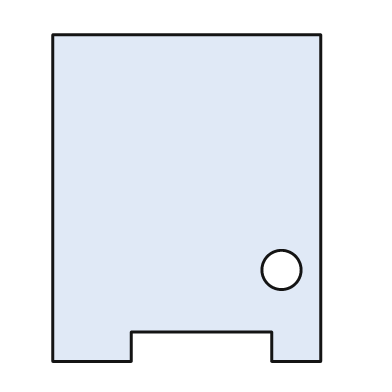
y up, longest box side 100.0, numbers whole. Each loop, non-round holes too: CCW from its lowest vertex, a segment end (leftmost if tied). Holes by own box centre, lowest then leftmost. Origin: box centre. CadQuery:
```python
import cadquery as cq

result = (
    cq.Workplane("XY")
    .moveTo(-41.0, -50.0)
    .lineTo(-17.0, -50.0)
    .lineTo(-17.0, -41.0)
    .lineTo(26.0, -41.0)
    .lineTo(26.0, -50.0)
    .lineTo(41.0, -50.0)
    .lineTo(41.0, 50.0)
    .lineTo(-41.0, 50.0)
    .close()
    .moveTo(29.0, -22.0)
    .circle(6.0)
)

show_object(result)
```